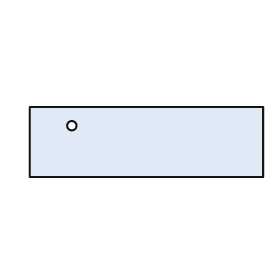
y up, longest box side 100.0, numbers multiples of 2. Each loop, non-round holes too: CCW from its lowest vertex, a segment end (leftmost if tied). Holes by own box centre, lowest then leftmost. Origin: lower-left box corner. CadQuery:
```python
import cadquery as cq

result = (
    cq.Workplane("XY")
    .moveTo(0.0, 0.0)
    .lineTo(100.0, 0.0)
    .lineTo(100.0, 30.0)
    .lineTo(0.0, 30.0)
    .close()
    .moveTo(18.0, 22.0)
    .circle(2.0)
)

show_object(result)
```